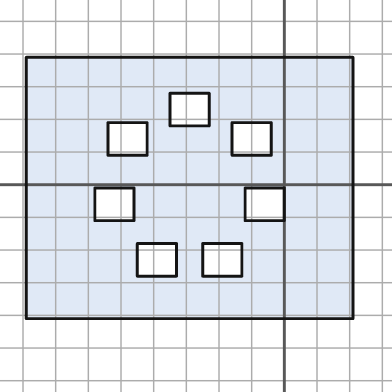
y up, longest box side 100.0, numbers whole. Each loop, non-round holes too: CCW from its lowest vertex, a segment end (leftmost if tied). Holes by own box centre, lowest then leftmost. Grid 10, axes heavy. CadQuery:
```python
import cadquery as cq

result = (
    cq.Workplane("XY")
    .moveTo(-79.0, -41.0)
    .lineTo(21.0, -41.0)
    .lineTo(21.0, 39.0)
    .lineTo(-79.0, 39.0)
    .close()
    .moveTo(-45.0, -28.0)
    .lineTo(-33.0, -28.0)
    .lineTo(-33.0, -18.0)
    .lineTo(-45.0, -18.0)
    .close()
    .moveTo(-25.0, -28.0)
    .lineTo(-13.0, -28.0)
    .lineTo(-13.0, -18.0)
    .lineTo(-25.0, -18.0)
    .close()
    .moveTo(-58.0, -11.0)
    .lineTo(-46.0, -11.0)
    .lineTo(-46.0, -1.0)
    .lineTo(-58.0, -1.0)
    .close()
    .moveTo(-12.0, -11.0)
    .lineTo(0.0, -11.0)
    .lineTo(0.0, -1.0)
    .lineTo(-12.0, -1.0)
    .close()
    .moveTo(-54.0, 9.0)
    .lineTo(-42.0, 9.0)
    .lineTo(-42.0, 19.0)
    .lineTo(-54.0, 19.0)
    .close()
    .moveTo(-16.0, 9.0)
    .lineTo(-4.0, 9.0)
    .lineTo(-4.0, 19.0)
    .lineTo(-16.0, 19.0)
    .close()
    .moveTo(-35.0, 18.0)
    .lineTo(-23.0, 18.0)
    .lineTo(-23.0, 28.0)
    .lineTo(-35.0, 28.0)
    .close()
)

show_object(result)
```